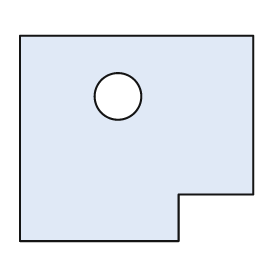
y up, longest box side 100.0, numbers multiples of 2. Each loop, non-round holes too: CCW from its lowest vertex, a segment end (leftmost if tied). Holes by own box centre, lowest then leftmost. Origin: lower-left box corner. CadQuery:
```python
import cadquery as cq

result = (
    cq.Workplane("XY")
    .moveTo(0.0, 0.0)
    .lineTo(68.0, 0.0)
    .lineTo(68.0, 20.0)
    .lineTo(100.0, 20.0)
    .lineTo(100.0, 88.0)
    .lineTo(0.0, 88.0)
    .close()
    .moveTo(42.0, 62.0)
    .circle(10.0)
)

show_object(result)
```